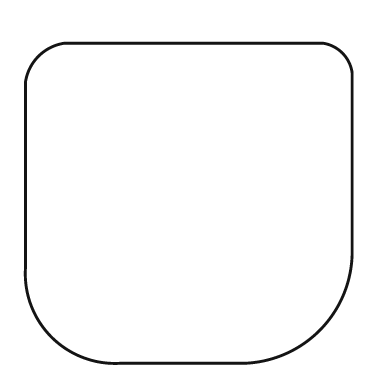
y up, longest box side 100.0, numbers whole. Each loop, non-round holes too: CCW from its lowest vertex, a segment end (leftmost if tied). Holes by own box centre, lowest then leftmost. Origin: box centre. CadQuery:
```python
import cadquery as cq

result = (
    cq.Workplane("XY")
    .moveTo(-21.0, -49.0)
    .lineTo(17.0, -49.0)
    .threePointArc((40.0, -39.0), (50.0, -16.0))
    .lineTo(50.0, 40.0)
    .threePointArc((47.0, 46.0), (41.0, 49.0))
    .lineTo(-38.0, 49.0)
    .threePointArc((-46.0, 45.0), (-50.0, 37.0))
    .lineTo(-50.0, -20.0)
    .threePointArc((-42.0, -41.0), (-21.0, -49.0))
    .close()
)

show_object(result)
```